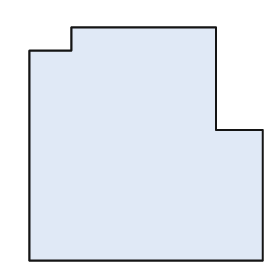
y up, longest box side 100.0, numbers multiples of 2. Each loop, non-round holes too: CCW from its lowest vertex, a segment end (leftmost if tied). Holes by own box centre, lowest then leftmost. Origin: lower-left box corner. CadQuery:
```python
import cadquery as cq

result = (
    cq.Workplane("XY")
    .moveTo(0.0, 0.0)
    .lineTo(100.0, 0.0)
    .lineTo(100.0, 56.0)
    .lineTo(80.0, 56.0)
    .lineTo(80.0, 100.0)
    .lineTo(18.0, 100.0)
    .lineTo(18.0, 90.0)
    .lineTo(0.0, 90.0)
    .close()
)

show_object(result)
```